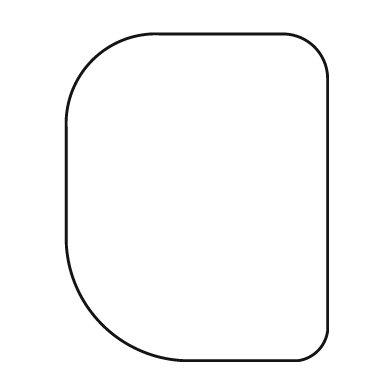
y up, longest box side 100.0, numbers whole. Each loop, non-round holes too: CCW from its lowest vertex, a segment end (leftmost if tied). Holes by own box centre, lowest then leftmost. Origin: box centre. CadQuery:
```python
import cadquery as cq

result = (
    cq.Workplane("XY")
    .moveTo(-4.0, -50.0)
    .lineTo(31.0, -50.0)
    .threePointArc((37.0, -47.0), (40.0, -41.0))
    .lineTo(40.0, 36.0)
    .threePointArc((36.0, 46.0), (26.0, 50.0))
    .lineTo(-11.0, 50.0)
    .threePointArc((-32.0, 42.0), (-40.0, 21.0))
    .lineTo(-40.0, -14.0)
    .threePointArc((-29.0, -39.0), (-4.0, -50.0))
    .close()
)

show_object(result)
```